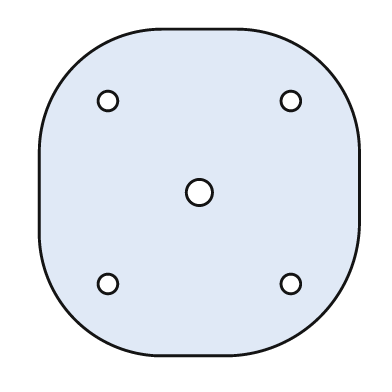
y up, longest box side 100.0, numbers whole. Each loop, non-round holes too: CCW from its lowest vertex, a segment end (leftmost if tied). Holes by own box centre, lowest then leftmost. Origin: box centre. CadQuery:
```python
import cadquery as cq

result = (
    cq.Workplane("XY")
    .moveTo(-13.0, -50.0)
    .lineTo(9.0, -50.0)
    .threePointArc((37.0, -38.0), (49.0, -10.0))
    .lineTo(49.0, 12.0)
    .threePointArc((38.0, 39.0), (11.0, 50.0))
    .lineTo(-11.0, 50.0)
    .threePointArc((-38.0, 39.0), (-49.0, 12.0))
    .lineTo(-49.0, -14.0)
    .threePointArc((-38.0, -39.0), (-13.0, -50.0))
    .close()
    .moveTo(-28.0, -28.0)
    .circle(3.0)
    .moveTo(28.0, -28.0)
    .circle(3.0)
    .moveTo(0.0, 0.0)
    .circle(4.0)
    .moveTo(-28.0, 28.0)
    .circle(3.0)
    .moveTo(28.0, 28.0)
    .circle(3.0)
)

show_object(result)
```